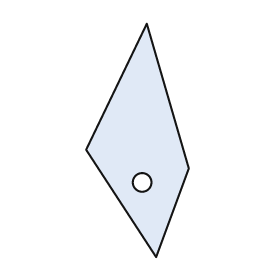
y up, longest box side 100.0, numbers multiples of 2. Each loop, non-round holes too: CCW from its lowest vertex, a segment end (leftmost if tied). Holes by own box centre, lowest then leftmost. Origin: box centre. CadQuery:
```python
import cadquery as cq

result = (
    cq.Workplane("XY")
    .moveTo(8.0, -50.0)
    .lineTo(22.0, -12.0)
    .lineTo(4.0, 50.0)
    .lineTo(-22.0, -4.0)
    .close()
    .moveTo(2.0, -18.0)
    .circle(4.0)
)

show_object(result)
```